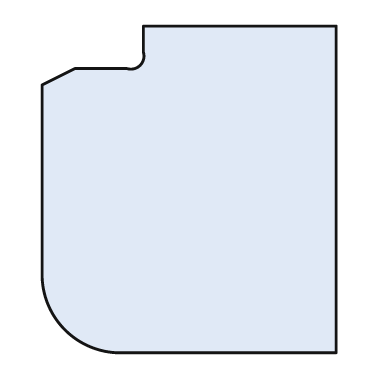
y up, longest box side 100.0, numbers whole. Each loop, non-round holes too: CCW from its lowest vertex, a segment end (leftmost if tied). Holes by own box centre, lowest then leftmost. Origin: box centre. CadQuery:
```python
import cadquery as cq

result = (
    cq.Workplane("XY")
    .moveTo(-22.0, -50.0)
    .lineTo(45.0, -50.0)
    .lineTo(45.0, 50.0)
    .lineTo(-14.0, 50.0)
    .lineTo(-14.0, 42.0)
    .threePointArc((-15.0, 38.0), (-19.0, 37.0))
    .lineTo(-35.0, 37.0)
    .lineTo(-45.0, 32.0)
    .lineTo(-45.0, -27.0)
    .threePointArc((-38.0, -43.0), (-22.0, -50.0))
    .close()
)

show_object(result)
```